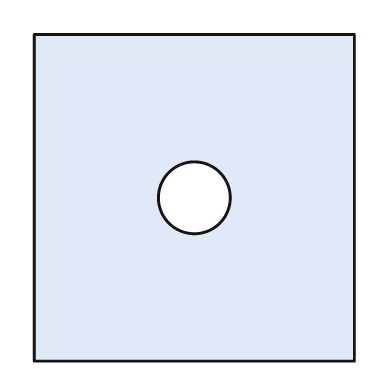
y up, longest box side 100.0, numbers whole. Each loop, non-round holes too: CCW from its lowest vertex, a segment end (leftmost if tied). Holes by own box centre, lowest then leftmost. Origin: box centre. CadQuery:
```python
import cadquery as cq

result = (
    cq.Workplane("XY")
    .moveTo(-49.0, -50.0)
    .lineTo(49.0, -50.0)
    .lineTo(49.0, 50.0)
    .lineTo(-49.0, 50.0)
    .close()
    .moveTo(0.0, 0.0)
    .circle(11.0)
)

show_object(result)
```